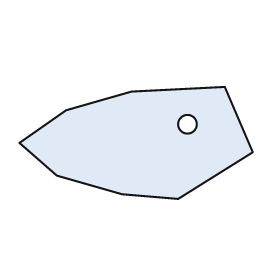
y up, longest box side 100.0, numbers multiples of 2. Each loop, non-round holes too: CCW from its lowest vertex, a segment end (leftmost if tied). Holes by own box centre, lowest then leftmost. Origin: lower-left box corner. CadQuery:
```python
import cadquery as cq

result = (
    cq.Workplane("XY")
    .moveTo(68.0, 0.0)
    .lineTo(100.0, 20.0)
    .lineTo(88.0, 48.0)
    .lineTo(48.0, 46.0)
    .lineTo(20.0, 38.0)
    .lineTo(0.0, 24.0)
    .lineTo(16.0, 10.0)
    .lineTo(44.0, 2.0)
    .close()
    .moveTo(72.0, 32.0)
    .circle(4.0)
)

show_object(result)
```